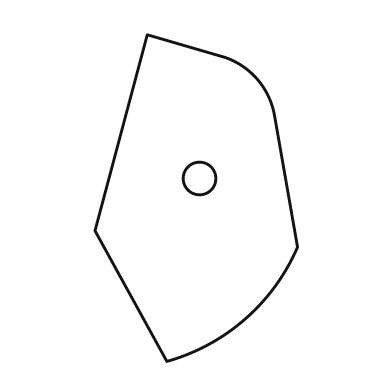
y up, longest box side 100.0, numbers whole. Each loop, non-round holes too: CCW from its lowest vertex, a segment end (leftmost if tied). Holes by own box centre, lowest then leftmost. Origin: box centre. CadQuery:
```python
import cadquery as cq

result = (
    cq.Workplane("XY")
    .moveTo(-9.0, -50.0)
    .threePointArc((15.0, -37.0), (31.0, -15.0))
    .lineTo(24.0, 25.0)
    .threePointArc((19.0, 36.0), (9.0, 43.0))
    .lineTo(-15.0, 50.0)
    .lineTo(-31.0, -10.0)
    .close()
    .moveTo(1.0, 6.0)
    .circle(5.0)
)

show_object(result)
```